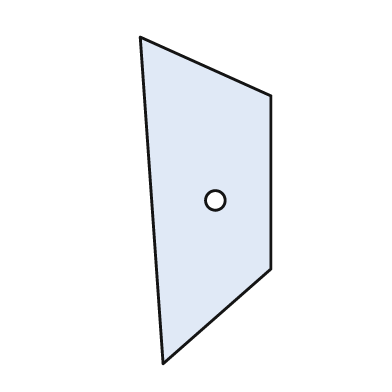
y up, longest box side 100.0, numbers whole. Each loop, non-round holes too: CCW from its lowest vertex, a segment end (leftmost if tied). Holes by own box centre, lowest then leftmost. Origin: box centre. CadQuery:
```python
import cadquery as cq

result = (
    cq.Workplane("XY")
    .moveTo(-13.0, -50.0)
    .lineTo(20.0, -21.0)
    .lineTo(20.0, 32.0)
    .lineTo(-20.0, 50.0)
    .close()
    .moveTo(3.0, 0.0)
    .circle(3.0)
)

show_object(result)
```